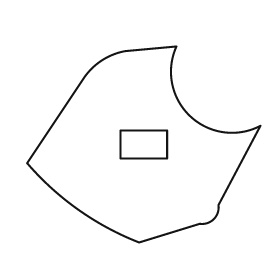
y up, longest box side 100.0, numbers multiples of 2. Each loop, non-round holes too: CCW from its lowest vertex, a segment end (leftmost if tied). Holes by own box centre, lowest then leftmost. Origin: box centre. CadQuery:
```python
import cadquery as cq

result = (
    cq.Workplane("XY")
    .moveTo(-2.0, -42.0)
    .lineTo(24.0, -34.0)
    .threePointArc((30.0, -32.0), (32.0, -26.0))
    .lineTo(50.0, 8.0)
    .threePointArc((20.0, 12.0), (14.0, 42.0))
    .lineTo(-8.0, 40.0)
    .threePointArc((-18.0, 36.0), (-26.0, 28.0))
    .lineTo(-50.0, -8.0)
    .threePointArc((-28.0, -28.0), (-2.0, -42.0))
    .close()
    .moveTo(-10.0, -6.0)
    .lineTo(10.0, -6.0)
    .lineTo(10.0, 6.0)
    .lineTo(-10.0, 6.0)
    .close()
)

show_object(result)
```